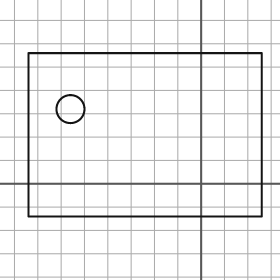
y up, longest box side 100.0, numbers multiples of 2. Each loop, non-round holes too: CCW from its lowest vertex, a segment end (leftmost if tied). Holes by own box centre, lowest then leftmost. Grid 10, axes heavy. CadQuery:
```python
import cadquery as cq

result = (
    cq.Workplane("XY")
    .moveTo(-74.0, -14.0)
    .lineTo(26.0, -14.0)
    .lineTo(26.0, 56.0)
    .lineTo(-74.0, 56.0)
    .close()
    .moveTo(-56.0, 32.0)
    .circle(6.0)
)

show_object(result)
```